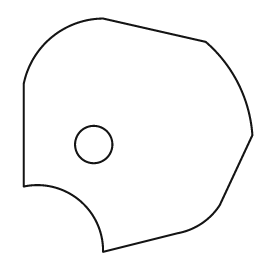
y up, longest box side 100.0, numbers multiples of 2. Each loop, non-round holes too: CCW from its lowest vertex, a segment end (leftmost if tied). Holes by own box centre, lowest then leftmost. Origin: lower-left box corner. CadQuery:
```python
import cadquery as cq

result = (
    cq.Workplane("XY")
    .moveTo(34.0, 0.0)
    .lineTo(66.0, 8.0)
    .threePointArc((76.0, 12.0), (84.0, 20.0))
    .lineTo(98.0, 50.0)
    .threePointArc((92.0, 72.0), (78.0, 90.0))
    .lineTo(34.0, 100.0)
    .threePointArc((12.0, 92.0), (0.0, 72.0))
    .lineTo(0.0, 28.0)
    .threePointArc((24.0, 22.0), (34.0, 0.0))
    .close()
    .moveTo(30.0, 46.0)
    .circle(8.0)
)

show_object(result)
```